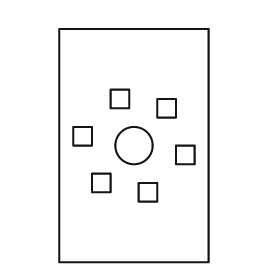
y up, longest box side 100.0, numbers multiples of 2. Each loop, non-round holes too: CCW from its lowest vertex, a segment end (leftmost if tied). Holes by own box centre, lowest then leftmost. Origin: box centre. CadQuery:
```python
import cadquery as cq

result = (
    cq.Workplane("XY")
    .moveTo(-32.0, -50.0)
    .lineTo(32.0, -50.0)
    .lineTo(32.0, 50.0)
    .lineTo(-32.0, 50.0)
    .close()
    .moveTo(2.0, -24.0)
    .lineTo(10.0, -24.0)
    .lineTo(10.0, -16.0)
    .lineTo(2.0, -16.0)
    .close()
    .moveTo(-18.0, -20.0)
    .lineTo(-10.0, -20.0)
    .lineTo(-10.0, -12.0)
    .lineTo(-18.0, -12.0)
    .close()
    .moveTo(18.0, -8.0)
    .lineTo(26.0, -8.0)
    .lineTo(26.0, 0.0)
    .lineTo(18.0, 0.0)
    .close()
    .moveTo(0.0, 0.0)
    .circle(8.0)
    .moveTo(-26.0, 0.0)
    .lineTo(-18.0, 0.0)
    .lineTo(-18.0, 8.0)
    .lineTo(-26.0, 8.0)
    .close()
    .moveTo(10.0, 12.0)
    .lineTo(18.0, 12.0)
    .lineTo(18.0, 20.0)
    .lineTo(10.0, 20.0)
    .close()
    .moveTo(-10.0, 16.0)
    .lineTo(-2.0, 16.0)
    .lineTo(-2.0, 24.0)
    .lineTo(-10.0, 24.0)
    .close()
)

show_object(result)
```